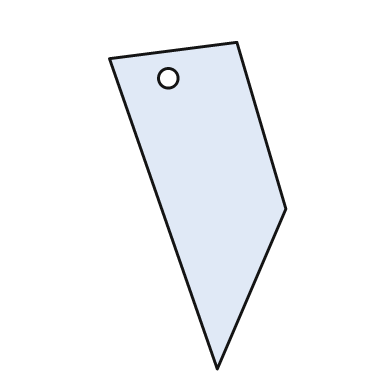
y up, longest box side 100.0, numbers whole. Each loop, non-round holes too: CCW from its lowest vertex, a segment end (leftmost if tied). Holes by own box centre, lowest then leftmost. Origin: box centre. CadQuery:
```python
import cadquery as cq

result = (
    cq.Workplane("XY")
    .moveTo(6.0, -50.0)
    .lineTo(27.0, -1.0)
    .lineTo(12.0, 50.0)
    .lineTo(-27.0, 45.0)
    .close()
    .moveTo(-9.0, 39.0)
    .circle(3.0)
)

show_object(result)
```